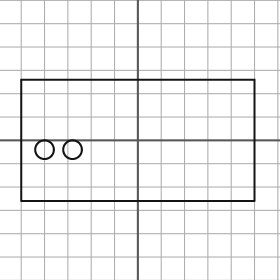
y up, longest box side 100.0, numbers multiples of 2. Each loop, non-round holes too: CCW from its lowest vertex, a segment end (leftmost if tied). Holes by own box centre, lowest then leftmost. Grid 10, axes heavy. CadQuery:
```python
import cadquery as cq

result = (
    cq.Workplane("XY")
    .moveTo(-50.0, -26.0)
    .lineTo(50.0, -26.0)
    .lineTo(50.0, 26.0)
    .lineTo(-50.0, 26.0)
    .close()
    .moveTo(-40.0, -4.0)
    .circle(4.0)
    .moveTo(-28.0, -4.0)
    .circle(4.0)
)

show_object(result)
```